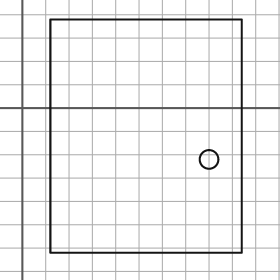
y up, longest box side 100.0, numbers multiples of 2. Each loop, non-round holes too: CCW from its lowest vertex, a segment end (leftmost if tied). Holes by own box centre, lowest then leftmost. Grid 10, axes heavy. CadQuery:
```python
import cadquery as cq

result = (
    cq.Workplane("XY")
    .moveTo(12.0, -62.0)
    .lineTo(94.0, -62.0)
    .lineTo(94.0, 38.0)
    .lineTo(12.0, 38.0)
    .close()
    .moveTo(80.0, -22.0)
    .circle(4.0)
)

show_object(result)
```